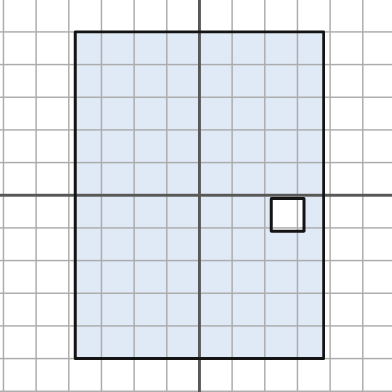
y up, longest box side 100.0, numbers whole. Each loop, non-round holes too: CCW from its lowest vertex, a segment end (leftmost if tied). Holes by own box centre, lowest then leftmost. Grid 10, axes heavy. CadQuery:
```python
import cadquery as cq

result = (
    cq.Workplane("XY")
    .moveTo(-38.0, -50.0)
    .lineTo(38.0, -50.0)
    .lineTo(38.0, 50.0)
    .lineTo(-38.0, 50.0)
    .close()
    .moveTo(22.0, -11.0)
    .lineTo(32.0, -11.0)
    .lineTo(32.0, -1.0)
    .lineTo(22.0, -1.0)
    .close()
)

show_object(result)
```